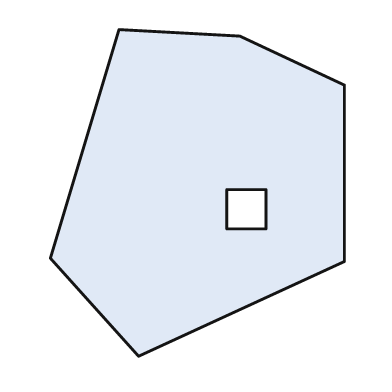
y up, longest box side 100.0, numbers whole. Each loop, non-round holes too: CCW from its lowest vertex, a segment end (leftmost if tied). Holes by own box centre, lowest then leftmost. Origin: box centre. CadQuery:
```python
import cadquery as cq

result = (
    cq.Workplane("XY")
    .moveTo(-18.0, -50.0)
    .lineTo(45.0, -21.0)
    .lineTo(45.0, 33.0)
    .lineTo(13.0, 48.0)
    .lineTo(-24.0, 50.0)
    .lineTo(-45.0, -20.0)
    .close()
    .moveTo(9.0, -11.0)
    .lineTo(21.0, -11.0)
    .lineTo(21.0, 1.0)
    .lineTo(9.0, 1.0)
    .close()
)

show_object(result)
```